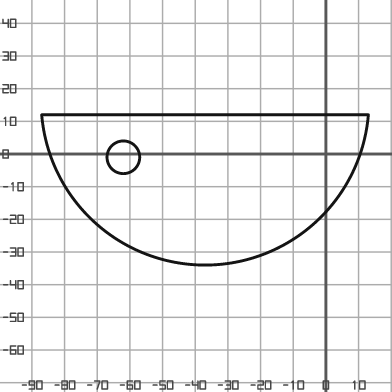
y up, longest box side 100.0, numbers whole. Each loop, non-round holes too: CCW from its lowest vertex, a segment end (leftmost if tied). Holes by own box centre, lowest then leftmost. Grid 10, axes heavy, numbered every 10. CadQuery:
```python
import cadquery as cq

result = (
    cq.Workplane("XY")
    .moveTo(-87.0, 12.0)
    .threePointArc((-37.0, -34.0), (13.0, 12.0))
    .close()
    .moveTo(-62.0, -1.0)
    .circle(5.0)
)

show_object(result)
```